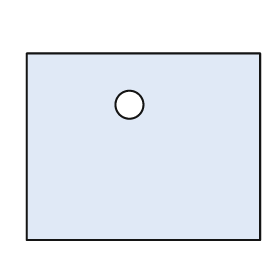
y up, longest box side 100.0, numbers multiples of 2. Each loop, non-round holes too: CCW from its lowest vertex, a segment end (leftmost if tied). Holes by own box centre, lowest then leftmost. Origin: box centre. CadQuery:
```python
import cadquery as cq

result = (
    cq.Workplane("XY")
    .moveTo(-50.0, -40.0)
    .lineTo(50.0, -40.0)
    .lineTo(50.0, 40.0)
    .lineTo(-50.0, 40.0)
    .close()
    .moveTo(-6.0, 18.0)
    .circle(6.0)
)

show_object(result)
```